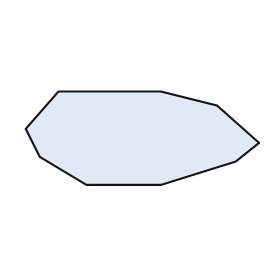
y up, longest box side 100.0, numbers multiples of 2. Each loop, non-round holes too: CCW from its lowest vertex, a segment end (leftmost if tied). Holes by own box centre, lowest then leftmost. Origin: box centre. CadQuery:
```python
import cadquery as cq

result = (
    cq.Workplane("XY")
    .moveTo(-24.0, -20.0)
    .lineTo(8.0, -20.0)
    .lineTo(40.0, -10.0)
    .lineTo(50.0, -2.0)
    .lineTo(32.0, 14.0)
    .lineTo(8.0, 20.0)
    .lineTo(-36.0, 20.0)
    .lineTo(-50.0, 4.0)
    .lineTo(-44.0, -8.0)
    .close()
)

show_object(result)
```